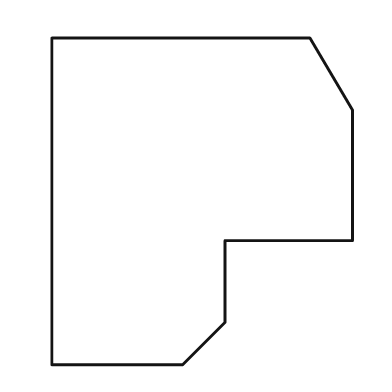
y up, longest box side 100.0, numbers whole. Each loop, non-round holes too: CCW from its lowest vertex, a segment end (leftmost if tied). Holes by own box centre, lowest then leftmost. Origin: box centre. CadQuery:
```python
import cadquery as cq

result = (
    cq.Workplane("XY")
    .moveTo(-46.0, -50.0)
    .lineTo(-6.0, -50.0)
    .lineTo(7.0, -37.0)
    .lineTo(7.0, -12.0)
    .lineTo(46.0, -12.0)
    .lineTo(46.0, 28.0)
    .lineTo(33.0, 50.0)
    .lineTo(-46.0, 50.0)
    .close()
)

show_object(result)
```